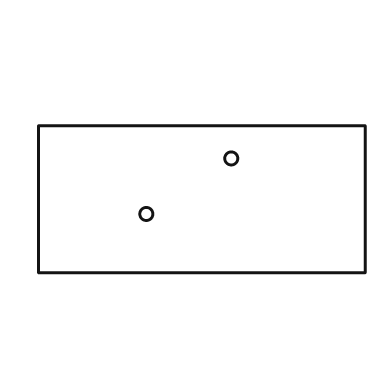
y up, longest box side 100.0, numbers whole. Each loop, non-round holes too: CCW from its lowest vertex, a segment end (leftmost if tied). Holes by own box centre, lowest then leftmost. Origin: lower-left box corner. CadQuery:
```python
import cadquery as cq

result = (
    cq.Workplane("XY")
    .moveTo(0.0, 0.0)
    .lineTo(100.0, 0.0)
    .lineTo(100.0, 45.0)
    .lineTo(0.0, 45.0)
    .close()
    .moveTo(33.0, 18.0)
    .circle(2.0)
    .moveTo(59.0, 35.0)
    .circle(2.0)
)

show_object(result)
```